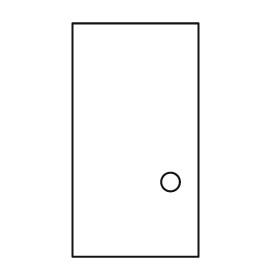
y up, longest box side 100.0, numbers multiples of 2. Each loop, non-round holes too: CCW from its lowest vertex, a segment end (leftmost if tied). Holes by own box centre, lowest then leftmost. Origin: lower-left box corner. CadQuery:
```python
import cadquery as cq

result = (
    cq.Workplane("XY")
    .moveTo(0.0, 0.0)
    .lineTo(54.0, 0.0)
    .lineTo(54.0, 100.0)
    .lineTo(0.0, 100.0)
    .close()
    .moveTo(42.0, 32.0)
    .circle(4.0)
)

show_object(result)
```